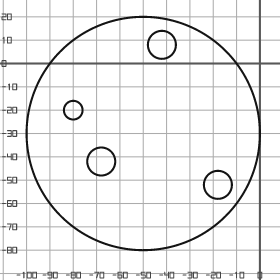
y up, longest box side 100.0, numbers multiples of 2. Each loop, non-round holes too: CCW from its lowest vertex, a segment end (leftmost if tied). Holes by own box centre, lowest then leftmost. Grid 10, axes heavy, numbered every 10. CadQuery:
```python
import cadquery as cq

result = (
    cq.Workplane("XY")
    .moveTo(-50.0, -30.0)
    .circle(50.0)
    .moveTo(-18.0, -52.0)
    .circle(6.0)
    .moveTo(-68.0, -42.0)
    .circle(6.0)
    .moveTo(-80.0, -20.0)
    .circle(4.0)
    .moveTo(-42.0, 8.0)
    .circle(6.0)
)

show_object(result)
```